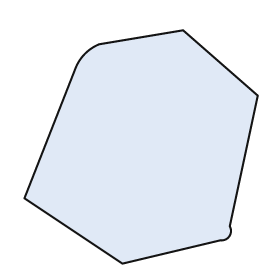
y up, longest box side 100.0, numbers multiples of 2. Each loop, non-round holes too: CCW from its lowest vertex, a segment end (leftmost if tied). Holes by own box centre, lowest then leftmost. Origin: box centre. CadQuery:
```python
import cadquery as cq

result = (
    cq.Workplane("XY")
    .moveTo(-8.0, -50.0)
    .lineTo(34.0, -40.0)
    .threePointArc((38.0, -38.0), (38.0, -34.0))
    .lineTo(50.0, 22.0)
    .lineTo(18.0, 50.0)
    .lineTo(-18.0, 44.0)
    .threePointArc((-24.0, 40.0), (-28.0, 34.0))
    .lineTo(-50.0, -22.0)
    .close()
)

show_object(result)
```